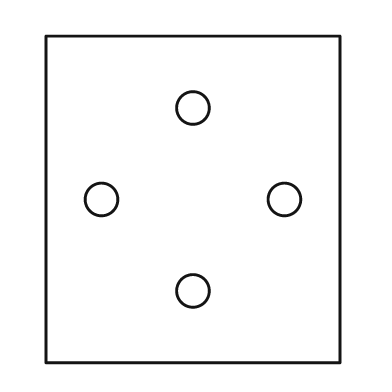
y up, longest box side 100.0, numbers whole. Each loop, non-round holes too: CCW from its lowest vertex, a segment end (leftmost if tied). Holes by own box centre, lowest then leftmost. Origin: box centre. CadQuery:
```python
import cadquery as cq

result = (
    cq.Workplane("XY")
    .moveTo(-45.0, -50.0)
    .lineTo(45.0, -50.0)
    .lineTo(45.0, 50.0)
    .lineTo(-45.0, 50.0)
    .close()
    .moveTo(0.0, -28.0)
    .circle(5.0)
    .moveTo(-28.0, 0.0)
    .circle(5.0)
    .moveTo(28.0, 0.0)
    .circle(5.0)
    .moveTo(0.0, 28.0)
    .circle(5.0)
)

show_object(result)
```